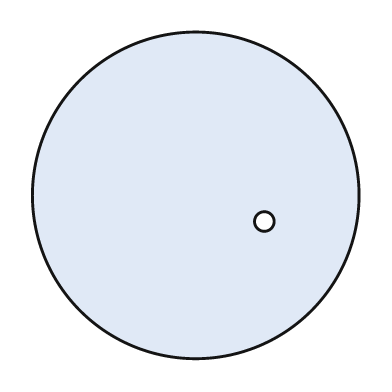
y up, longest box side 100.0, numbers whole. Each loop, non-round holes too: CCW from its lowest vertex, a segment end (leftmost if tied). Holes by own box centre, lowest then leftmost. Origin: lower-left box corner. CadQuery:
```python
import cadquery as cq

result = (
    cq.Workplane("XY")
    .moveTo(50.0, 50.0)
    .circle(50.0)
    .moveTo(71.0, 42.0)
    .circle(3.0)
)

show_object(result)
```